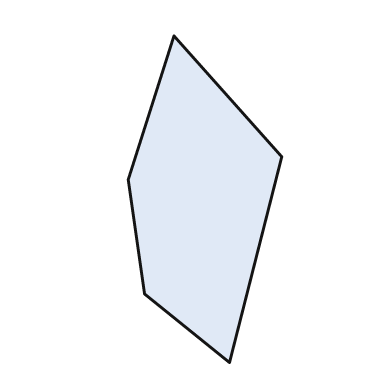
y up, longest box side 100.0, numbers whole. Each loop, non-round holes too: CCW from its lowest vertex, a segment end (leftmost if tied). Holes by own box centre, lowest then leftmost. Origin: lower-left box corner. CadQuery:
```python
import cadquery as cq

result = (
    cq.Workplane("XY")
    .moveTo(31.0, 0.0)
    .lineTo(47.0, 63.0)
    .lineTo(14.0, 100.0)
    .lineTo(0.0, 56.0)
    .lineTo(5.0, 21.0)
    .close()
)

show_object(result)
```